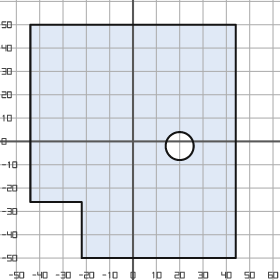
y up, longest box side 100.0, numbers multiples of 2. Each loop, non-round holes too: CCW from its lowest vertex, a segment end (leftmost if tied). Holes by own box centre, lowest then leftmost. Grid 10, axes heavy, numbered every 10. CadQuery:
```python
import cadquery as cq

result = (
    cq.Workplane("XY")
    .moveTo(-22.0, -50.0)
    .lineTo(44.0, -50.0)
    .lineTo(44.0, 50.0)
    .lineTo(-44.0, 50.0)
    .lineTo(-44.0, -26.0)
    .lineTo(-22.0, -26.0)
    .close()
    .moveTo(20.0, -2.0)
    .circle(6.0)
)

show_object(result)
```